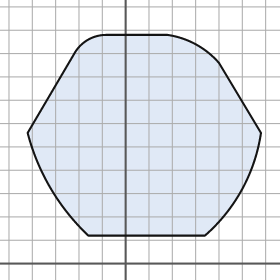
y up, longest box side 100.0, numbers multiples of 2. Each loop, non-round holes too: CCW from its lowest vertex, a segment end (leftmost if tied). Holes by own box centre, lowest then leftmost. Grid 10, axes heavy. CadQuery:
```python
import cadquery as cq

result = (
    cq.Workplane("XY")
    .moveTo(-16.0, 12.0)
    .lineTo(34.0, 12.0)
    .threePointArc((50.0, 32.0), (58.0, 56.0))
    .lineTo(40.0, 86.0)
    .threePointArc((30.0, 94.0), (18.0, 98.0))
    .lineTo(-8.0, 98.0)
    .threePointArc((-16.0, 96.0), (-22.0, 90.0))
    .lineTo(-42.0, 56.0)
    .threePointArc((-32.0, 32.0), (-16.0, 12.0))
    .close()
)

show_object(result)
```